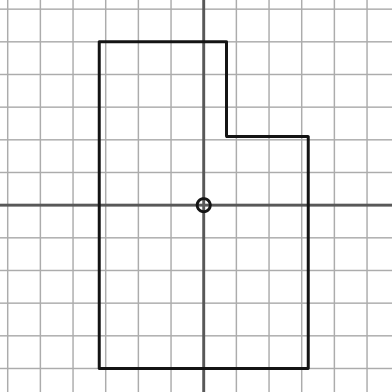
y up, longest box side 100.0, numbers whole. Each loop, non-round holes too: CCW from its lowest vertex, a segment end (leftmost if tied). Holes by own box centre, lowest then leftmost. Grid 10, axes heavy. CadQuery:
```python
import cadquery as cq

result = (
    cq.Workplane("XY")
    .moveTo(-32.0, -50.0)
    .lineTo(32.0, -50.0)
    .lineTo(32.0, 21.0)
    .lineTo(7.0, 21.0)
    .lineTo(7.0, 50.0)
    .lineTo(-32.0, 50.0)
    .close()
    .moveTo(0.0, 0.0)
    .circle(2.0)
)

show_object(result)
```